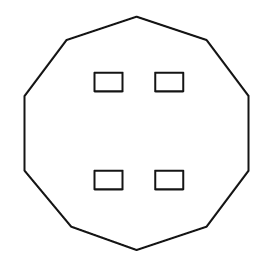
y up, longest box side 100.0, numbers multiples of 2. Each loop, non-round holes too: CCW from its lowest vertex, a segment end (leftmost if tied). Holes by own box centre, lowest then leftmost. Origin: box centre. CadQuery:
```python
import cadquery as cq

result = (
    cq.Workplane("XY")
    .moveTo(0.0, -50.0)
    .lineTo(30.0, -40.0)
    .lineTo(48.0, -16.0)
    .lineTo(48.0, 16.0)
    .lineTo(30.0, 40.0)
    .lineTo(0.0, 50.0)
    .lineTo(-30.0, 40.0)
    .lineTo(-48.0, 16.0)
    .lineTo(-48.0, -16.0)
    .lineTo(-28.0, -40.0)
    .close()
    .moveTo(-18.0, -24.0)
    .lineTo(-6.0, -24.0)
    .lineTo(-6.0, -16.0)
    .lineTo(-18.0, -16.0)
    .close()
    .moveTo(8.0, -24.0)
    .lineTo(20.0, -24.0)
    .lineTo(20.0, -16.0)
    .lineTo(8.0, -16.0)
    .close()
    .moveTo(-18.0, 18.0)
    .lineTo(-6.0, 18.0)
    .lineTo(-6.0, 26.0)
    .lineTo(-18.0, 26.0)
    .close()
    .moveTo(8.0, 18.0)
    .lineTo(20.0, 18.0)
    .lineTo(20.0, 26.0)
    .lineTo(8.0, 26.0)
    .close()
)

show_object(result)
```